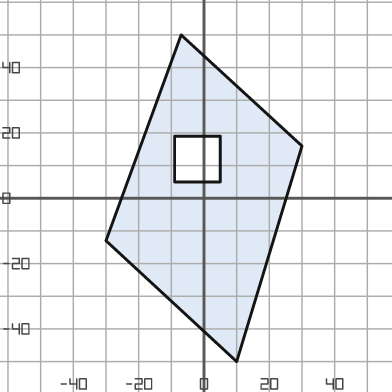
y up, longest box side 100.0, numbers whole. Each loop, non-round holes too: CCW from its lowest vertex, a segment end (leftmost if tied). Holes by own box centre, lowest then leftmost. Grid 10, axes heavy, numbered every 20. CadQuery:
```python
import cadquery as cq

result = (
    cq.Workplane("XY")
    .moveTo(10.0, -50.0)
    .lineTo(30.0, 16.0)
    .lineTo(-7.0, 50.0)
    .lineTo(-30.0, -13.0)
    .close()
    .moveTo(-9.0, 5.0)
    .lineTo(5.0, 5.0)
    .lineTo(5.0, 19.0)
    .lineTo(-9.0, 19.0)
    .close()
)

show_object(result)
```